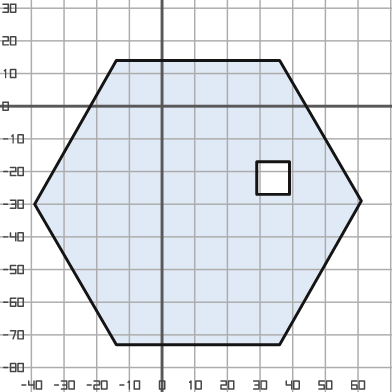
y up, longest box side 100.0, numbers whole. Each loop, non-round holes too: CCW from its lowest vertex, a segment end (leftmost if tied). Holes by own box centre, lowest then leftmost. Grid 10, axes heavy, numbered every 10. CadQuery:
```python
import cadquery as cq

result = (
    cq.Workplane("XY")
    .moveTo(-14.0, -73.0)
    .lineTo(36.0, -73.0)
    .lineTo(61.0, -29.0)
    .lineTo(36.0, 14.0)
    .lineTo(-14.0, 14.0)
    .lineTo(-39.0, -30.0)
    .close()
    .moveTo(29.0, -27.0)
    .lineTo(39.0, -27.0)
    .lineTo(39.0, -17.0)
    .lineTo(29.0, -17.0)
    .close()
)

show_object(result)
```